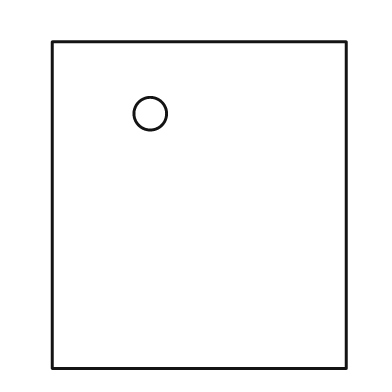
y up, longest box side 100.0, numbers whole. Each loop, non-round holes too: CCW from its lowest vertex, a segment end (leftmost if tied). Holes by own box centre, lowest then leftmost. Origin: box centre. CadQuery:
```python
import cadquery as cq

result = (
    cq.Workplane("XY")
    .moveTo(-45.0, -50.0)
    .lineTo(45.0, -50.0)
    .lineTo(45.0, 50.0)
    .lineTo(-45.0, 50.0)
    .close()
    .moveTo(-15.0, 28.0)
    .circle(5.0)
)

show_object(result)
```